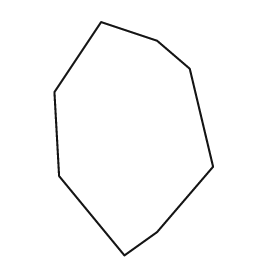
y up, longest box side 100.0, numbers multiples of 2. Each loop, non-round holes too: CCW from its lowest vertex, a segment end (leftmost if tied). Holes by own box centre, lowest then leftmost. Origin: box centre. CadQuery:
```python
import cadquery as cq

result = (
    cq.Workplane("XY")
    .moveTo(-4.0, -50.0)
    .lineTo(10.0, -40.0)
    .lineTo(34.0, -12.0)
    .lineTo(24.0, 30.0)
    .lineTo(10.0, 42.0)
    .lineTo(-14.0, 50.0)
    .lineTo(-34.0, 20.0)
    .lineTo(-32.0, -16.0)
    .close()
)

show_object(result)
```